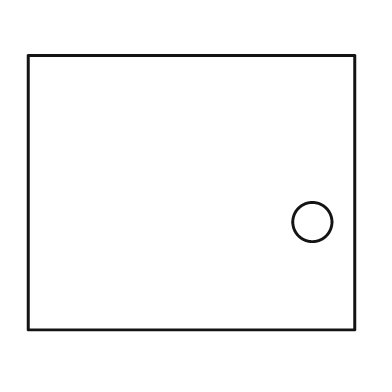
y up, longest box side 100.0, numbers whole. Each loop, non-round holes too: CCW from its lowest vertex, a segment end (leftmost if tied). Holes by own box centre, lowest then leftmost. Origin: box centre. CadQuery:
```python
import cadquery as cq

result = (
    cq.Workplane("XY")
    .moveTo(-50.0, -42.0)
    .lineTo(50.0, -42.0)
    .lineTo(50.0, 42.0)
    .lineTo(-50.0, 42.0)
    .close()
    .moveTo(37.0, -9.0)
    .circle(6.0)
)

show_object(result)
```